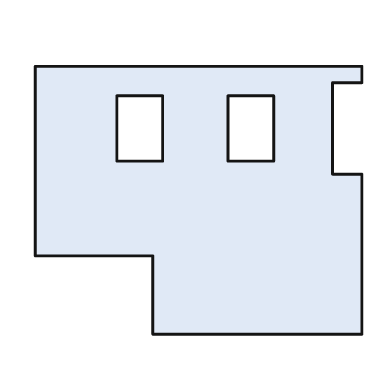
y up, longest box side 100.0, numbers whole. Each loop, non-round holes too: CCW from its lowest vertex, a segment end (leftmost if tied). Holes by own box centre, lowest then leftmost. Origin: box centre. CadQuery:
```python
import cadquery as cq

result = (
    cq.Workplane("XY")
    .moveTo(-14.0, -41.0)
    .lineTo(50.0, -41.0)
    .lineTo(50.0, 8.0)
    .lineTo(41.0, 8.0)
    .lineTo(41.0, 36.0)
    .lineTo(50.0, 36.0)
    .lineTo(50.0, 41.0)
    .lineTo(-50.0, 41.0)
    .lineTo(-50.0, -17.0)
    .lineTo(-14.0, -17.0)
    .close()
    .moveTo(-25.0, 12.0)
    .lineTo(-11.0, 12.0)
    .lineTo(-11.0, 32.0)
    .lineTo(-25.0, 32.0)
    .close()
    .moveTo(9.0, 12.0)
    .lineTo(23.0, 12.0)
    .lineTo(23.0, 32.0)
    .lineTo(9.0, 32.0)
    .close()
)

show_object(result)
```